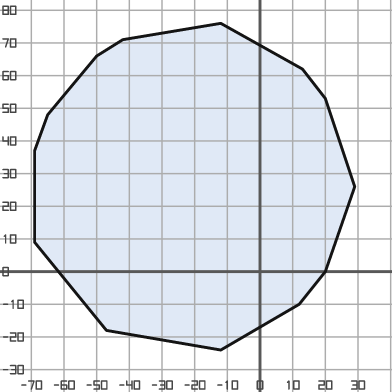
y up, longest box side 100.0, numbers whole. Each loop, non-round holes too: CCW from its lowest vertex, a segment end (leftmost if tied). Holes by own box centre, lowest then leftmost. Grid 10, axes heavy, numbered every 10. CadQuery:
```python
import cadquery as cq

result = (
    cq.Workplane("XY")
    .moveTo(-12.0, -24.0)
    .lineTo(12.0, -10.0)
    .lineTo(20.0, 0.0)
    .lineTo(29.0, 26.0)
    .lineTo(20.0, 53.0)
    .lineTo(13.0, 62.0)
    .lineTo(-12.0, 76.0)
    .lineTo(-42.0, 71.0)
    .lineTo(-50.0, 66.0)
    .lineTo(-65.0, 48.0)
    .lineTo(-69.0, 37.0)
    .lineTo(-69.0, 9.0)
    .lineTo(-47.0, -18.0)
    .close()
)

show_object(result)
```